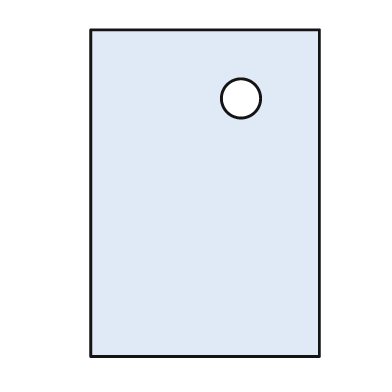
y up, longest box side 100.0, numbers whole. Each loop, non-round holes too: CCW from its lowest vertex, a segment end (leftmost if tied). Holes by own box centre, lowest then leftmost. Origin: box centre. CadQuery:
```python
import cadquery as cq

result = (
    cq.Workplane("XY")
    .moveTo(-35.0, -50.0)
    .lineTo(35.0, -50.0)
    .lineTo(35.0, 50.0)
    .lineTo(-35.0, 50.0)
    .close()
    .moveTo(11.0, 29.0)
    .circle(6.0)
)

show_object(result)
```